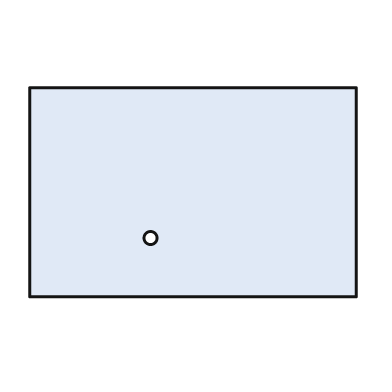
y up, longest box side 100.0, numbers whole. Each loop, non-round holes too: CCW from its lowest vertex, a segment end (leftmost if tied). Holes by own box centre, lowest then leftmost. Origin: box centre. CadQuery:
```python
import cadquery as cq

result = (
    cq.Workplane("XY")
    .moveTo(-50.0, -32.0)
    .lineTo(50.0, -32.0)
    .lineTo(50.0, 32.0)
    .lineTo(-50.0, 32.0)
    .close()
    .moveTo(-13.0, -14.0)
    .circle(2.0)
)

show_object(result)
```